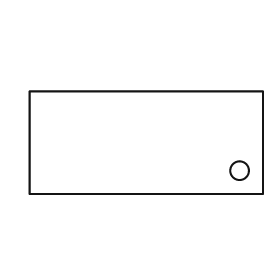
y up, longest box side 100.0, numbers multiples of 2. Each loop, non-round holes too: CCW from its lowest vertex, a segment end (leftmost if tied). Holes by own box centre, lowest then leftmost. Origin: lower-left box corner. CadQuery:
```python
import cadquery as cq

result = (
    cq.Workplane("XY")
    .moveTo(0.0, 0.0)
    .lineTo(100.0, 0.0)
    .lineTo(100.0, 44.0)
    .lineTo(0.0, 44.0)
    .close()
    .moveTo(90.0, 10.0)
    .circle(4.0)
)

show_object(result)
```